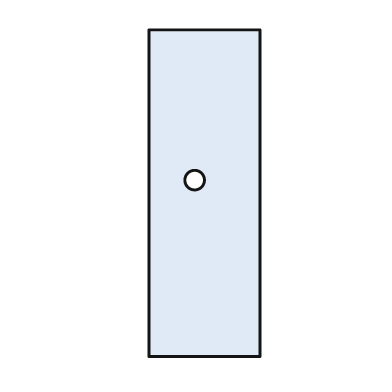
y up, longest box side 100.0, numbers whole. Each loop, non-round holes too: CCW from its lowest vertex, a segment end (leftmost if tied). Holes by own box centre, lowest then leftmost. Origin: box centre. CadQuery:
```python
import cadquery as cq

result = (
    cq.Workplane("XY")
    .moveTo(-17.0, -50.0)
    .lineTo(17.0, -50.0)
    .lineTo(17.0, 50.0)
    .lineTo(-17.0, 50.0)
    .close()
    .moveTo(-3.0, 4.0)
    .circle(3.0)
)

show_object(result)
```